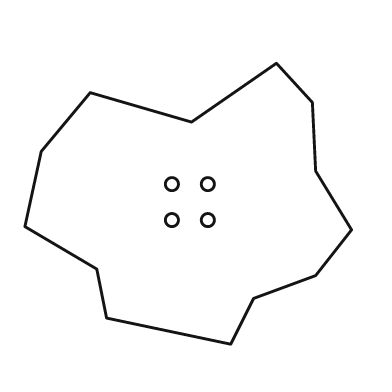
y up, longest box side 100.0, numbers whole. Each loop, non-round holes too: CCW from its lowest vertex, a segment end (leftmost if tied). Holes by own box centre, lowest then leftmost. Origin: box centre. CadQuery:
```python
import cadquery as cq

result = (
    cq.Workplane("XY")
    .moveTo(13.0, -43.0)
    .lineTo(20.0, -29.0)
    .lineTo(39.0, -22.0)
    .lineTo(50.0, -8.0)
    .lineTo(39.0, 10.0)
    .lineTo(38.0, 31.0)
    .lineTo(27.0, 43.0)
    .lineTo(1.0, 25.0)
    .lineTo(-30.0, 34.0)
    .lineTo(-45.0, 16.0)
    .lineTo(-50.0, -7.0)
    .lineTo(-28.0, -20.0)
    .lineTo(-25.0, -35.0)
    .close()
    .moveTo(-5.0, -5.0)
    .circle(2.0)
    .moveTo(6.0, -5.0)
    .circle(2.0)
    .moveTo(-5.0, 6.0)
    .circle(2.0)
    .moveTo(6.0, 6.0)
    .circle(2.0)
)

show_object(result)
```